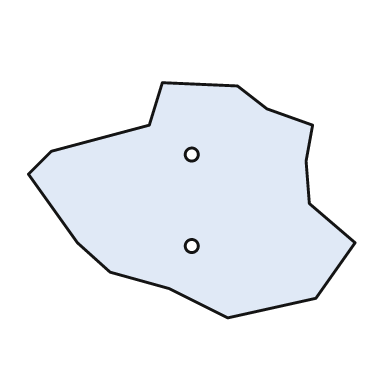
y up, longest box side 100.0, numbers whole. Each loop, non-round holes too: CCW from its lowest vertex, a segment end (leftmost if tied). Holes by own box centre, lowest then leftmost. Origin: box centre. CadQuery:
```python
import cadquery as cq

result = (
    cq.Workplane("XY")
    .moveTo(11.0, -36.0)
    .lineTo(38.0, -30.0)
    .lineTo(50.0, -13.0)
    .lineTo(36.0, -1.0)
    .lineTo(35.0, 12.0)
    .lineTo(37.0, 23.0)
    .lineTo(23.0, 28.0)
    .lineTo(14.0, 35.0)
    .lineTo(-9.0, 36.0)
    .lineTo(-13.0, 23.0)
    .lineTo(-43.0, 15.0)
    .lineTo(-50.0, 8.0)
    .lineTo(-35.0, -13.0)
    .lineTo(-25.0, -22.0)
    .lineTo(-7.0, -27.0)
    .close()
    .moveTo(0.0, -14.0)
    .circle(2.0)
    .moveTo(0.0, 14.0)
    .circle(2.0)
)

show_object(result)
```